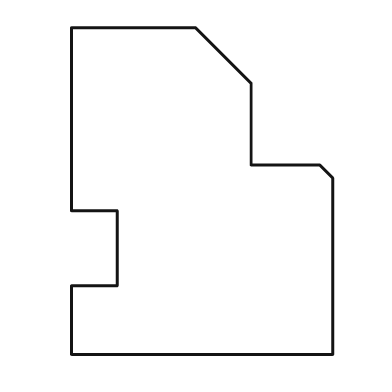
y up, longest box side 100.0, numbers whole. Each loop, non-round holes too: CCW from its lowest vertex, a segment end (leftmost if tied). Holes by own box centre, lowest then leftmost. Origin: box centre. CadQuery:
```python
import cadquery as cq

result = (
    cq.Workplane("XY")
    .moveTo(-40.0, -50.0)
    .lineTo(40.0, -50.0)
    .lineTo(40.0, 4.0)
    .lineTo(36.0, 8.0)
    .lineTo(15.0, 8.0)
    .lineTo(15.0, 33.0)
    .lineTo(-2.0, 50.0)
    .lineTo(-40.0, 50.0)
    .lineTo(-40.0, -6.0)
    .lineTo(-26.0, -6.0)
    .lineTo(-26.0, -29.0)
    .lineTo(-40.0, -29.0)
    .close()
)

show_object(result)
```